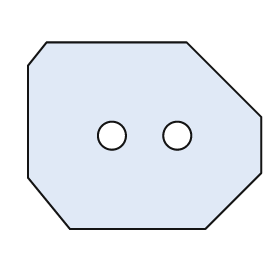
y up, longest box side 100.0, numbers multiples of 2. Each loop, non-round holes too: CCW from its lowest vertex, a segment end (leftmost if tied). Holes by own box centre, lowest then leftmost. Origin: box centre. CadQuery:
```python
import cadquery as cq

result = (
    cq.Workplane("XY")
    .moveTo(-32.0, -40.0)
    .lineTo(26.0, -40.0)
    .lineTo(50.0, -16.0)
    .lineTo(50.0, 8.0)
    .lineTo(18.0, 40.0)
    .lineTo(-42.0, 40.0)
    .lineTo(-50.0, 30.0)
    .lineTo(-50.0, -18.0)
    .close()
    .moveTo(-14.0, 0.0)
    .circle(6.0)
    .moveTo(14.0, 0.0)
    .circle(6.0)
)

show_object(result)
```